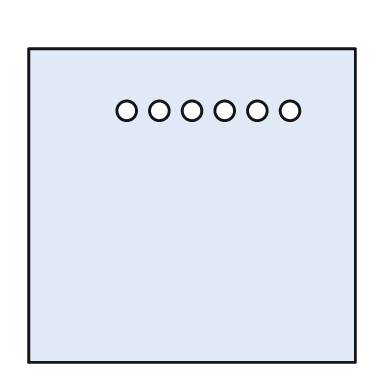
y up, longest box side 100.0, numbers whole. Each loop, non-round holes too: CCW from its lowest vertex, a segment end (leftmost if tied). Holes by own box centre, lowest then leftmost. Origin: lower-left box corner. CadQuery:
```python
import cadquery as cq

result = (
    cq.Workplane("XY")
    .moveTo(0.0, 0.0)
    .lineTo(100.0, 0.0)
    .lineTo(100.0, 96.0)
    .lineTo(0.0, 96.0)
    .close()
    .moveTo(30.0, 77.0)
    .circle(3.0)
    .moveTo(40.0, 77.0)
    .circle(3.0)
    .moveTo(50.0, 77.0)
    .circle(3.0)
    .moveTo(60.0, 77.0)
    .circle(3.0)
    .moveTo(70.0, 77.0)
    .circle(3.0)
    .moveTo(80.0, 77.0)
    .circle(3.0)
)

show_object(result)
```